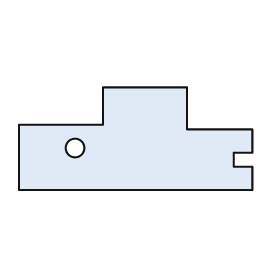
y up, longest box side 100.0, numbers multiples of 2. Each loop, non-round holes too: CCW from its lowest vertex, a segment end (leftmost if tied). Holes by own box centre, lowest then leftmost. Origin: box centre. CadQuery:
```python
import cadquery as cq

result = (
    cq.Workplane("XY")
    .moveTo(-50.0, -22.0)
    .lineTo(50.0, -22.0)
    .lineTo(50.0, -12.0)
    .lineTo(42.0, -12.0)
    .lineTo(42.0, -6.0)
    .lineTo(50.0, -6.0)
    .lineTo(50.0, 4.0)
    .lineTo(22.0, 4.0)
    .lineTo(22.0, 22.0)
    .lineTo(-14.0, 22.0)
    .lineTo(-14.0, 6.0)
    .lineTo(-50.0, 6.0)
    .close()
    .moveTo(-26.0, -4.0)
    .circle(4.0)
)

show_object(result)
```